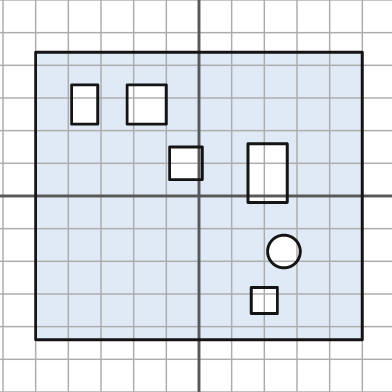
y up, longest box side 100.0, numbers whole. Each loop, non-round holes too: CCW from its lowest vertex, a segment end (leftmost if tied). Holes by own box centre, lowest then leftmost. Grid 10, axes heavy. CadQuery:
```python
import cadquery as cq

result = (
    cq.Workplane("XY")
    .moveTo(-50.0, -44.0)
    .lineTo(50.0, -44.0)
    .lineTo(50.0, 44.0)
    .lineTo(-50.0, 44.0)
    .close()
    .moveTo(16.0, -36.0)
    .lineTo(24.0, -36.0)
    .lineTo(24.0, -28.0)
    .lineTo(16.0, -28.0)
    .close()
    .moveTo(26.0, -17.0)
    .circle(5.0)
    .moveTo(15.0, -2.0)
    .lineTo(27.0, -2.0)
    .lineTo(27.0, 16.0)
    .lineTo(15.0, 16.0)
    .close()
    .moveTo(-9.0, 5.0)
    .lineTo(1.0, 5.0)
    .lineTo(1.0, 15.0)
    .lineTo(-9.0, 15.0)
    .close()
    .moveTo(-39.0, 22.0)
    .lineTo(-31.0, 22.0)
    .lineTo(-31.0, 34.0)
    .lineTo(-39.0, 34.0)
    .close()
    .moveTo(-22.0, 22.0)
    .lineTo(-10.0, 22.0)
    .lineTo(-10.0, 34.0)
    .lineTo(-22.0, 34.0)
    .close()
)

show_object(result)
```